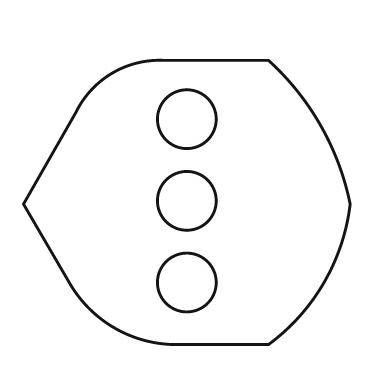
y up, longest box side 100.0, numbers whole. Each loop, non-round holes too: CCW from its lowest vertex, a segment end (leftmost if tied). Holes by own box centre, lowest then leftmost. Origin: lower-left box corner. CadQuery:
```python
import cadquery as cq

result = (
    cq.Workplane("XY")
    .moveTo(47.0, 0.0)
    .lineTo(75.0, 0.0)
    .threePointArc((92.0, 19.0), (100.0, 43.0))
    .threePointArc((91.0, 67.0), (75.0, 87.0))
    .lineTo(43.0, 87.0)
    .threePointArc((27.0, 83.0), (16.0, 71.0))
    .lineTo(0.0, 43.0)
    .lineTo(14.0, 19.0)
    .threePointArc((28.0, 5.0), (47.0, 0.0))
    .close()
    .moveTo(50.0, 19.0)
    .circle(9.0)
    .moveTo(50.0, 44.0)
    .circle(9.0)
    .moveTo(50.0, 69.0)
    .circle(9.0)
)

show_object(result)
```